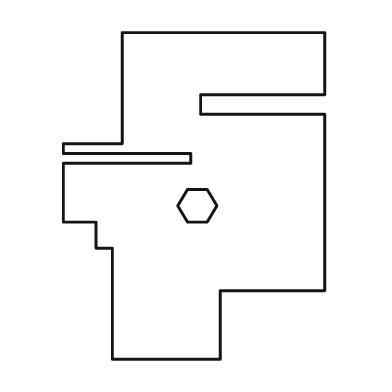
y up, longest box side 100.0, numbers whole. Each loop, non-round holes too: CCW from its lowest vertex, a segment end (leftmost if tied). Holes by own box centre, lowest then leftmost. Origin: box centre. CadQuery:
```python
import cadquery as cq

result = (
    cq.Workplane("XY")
    .moveTo(-25.0, -50.0)
    .lineTo(8.0, -50.0)
    .lineTo(8.0, -29.0)
    .lineTo(40.0, -29.0)
    .lineTo(40.0, 25.0)
    .lineTo(2.0, 25.0)
    .lineTo(2.0, 31.0)
    .lineTo(40.0, 31.0)
    .lineTo(40.0, 50.0)
    .lineTo(-22.0, 50.0)
    .lineTo(-22.0, 16.0)
    .lineTo(-40.0, 16.0)
    .lineTo(-40.0, 13.0)
    .lineTo(-1.0, 13.0)
    .lineTo(-1.0, 10.0)
    .lineTo(-40.0, 10.0)
    .lineTo(-40.0, -8.0)
    .lineTo(-30.0, -8.0)
    .lineTo(-30.0, -16.0)
    .lineTo(-25.0, -16.0)
    .close()
    .moveTo(-2.0, -8.0)
    .lineTo(4.0, -8.0)
    .lineTo(7.0, -3.0)
    .lineTo(4.0, 2.0)
    .lineTo(-2.0, 2.0)
    .lineTo(-5.0, -3.0)
    .close()
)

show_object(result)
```